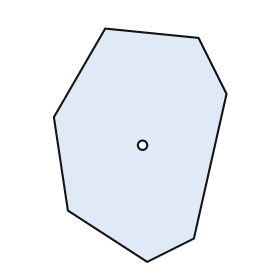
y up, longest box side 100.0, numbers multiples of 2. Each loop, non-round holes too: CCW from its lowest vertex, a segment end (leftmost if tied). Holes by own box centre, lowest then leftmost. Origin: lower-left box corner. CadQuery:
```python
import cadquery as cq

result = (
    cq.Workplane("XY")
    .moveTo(40.0, 0.0)
    .lineTo(60.0, 10.0)
    .lineTo(74.0, 72.0)
    .lineTo(62.0, 96.0)
    .lineTo(22.0, 100.0)
    .lineTo(0.0, 62.0)
    .lineTo(6.0, 22.0)
    .close()
    .moveTo(38.0, 50.0)
    .circle(2.0)
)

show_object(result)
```